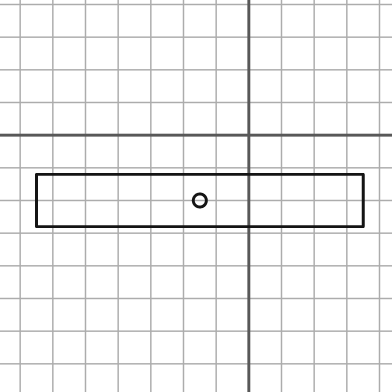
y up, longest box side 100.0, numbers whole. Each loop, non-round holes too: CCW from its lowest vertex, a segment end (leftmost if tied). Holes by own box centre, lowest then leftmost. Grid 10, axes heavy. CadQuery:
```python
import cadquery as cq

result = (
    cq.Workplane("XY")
    .moveTo(-65.0, -28.0)
    .lineTo(35.0, -28.0)
    .lineTo(35.0, -12.0)
    .lineTo(-65.0, -12.0)
    .close()
    .moveTo(-15.0, -20.0)
    .circle(2.0)
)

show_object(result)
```